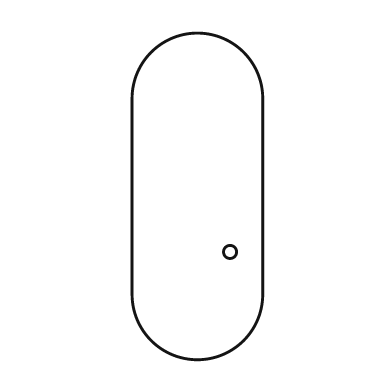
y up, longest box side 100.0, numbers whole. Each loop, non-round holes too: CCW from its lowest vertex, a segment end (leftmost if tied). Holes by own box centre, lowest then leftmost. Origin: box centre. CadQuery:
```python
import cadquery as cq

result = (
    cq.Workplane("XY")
    .moveTo(-20.0, -30.0)
    .threePointArc((0.0, -50.0), (20.0, -30.0))
    .lineTo(20.0, 30.0)
    .threePointArc((0.0, 50.0), (-20.0, 30.0))
    .close()
    .moveTo(10.0, -17.0)
    .circle(2.0)
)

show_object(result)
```